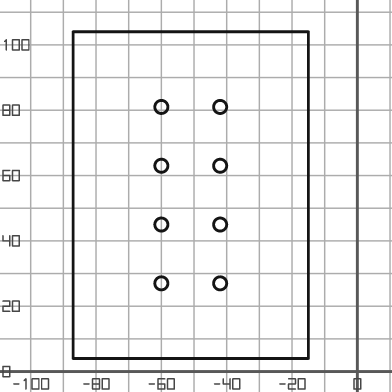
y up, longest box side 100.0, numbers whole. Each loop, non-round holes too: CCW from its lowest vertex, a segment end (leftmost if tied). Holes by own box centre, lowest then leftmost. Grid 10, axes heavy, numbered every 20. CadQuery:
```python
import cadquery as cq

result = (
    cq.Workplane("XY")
    .moveTo(-87.0, 4.0)
    .lineTo(-15.0, 4.0)
    .lineTo(-15.0, 104.0)
    .lineTo(-87.0, 104.0)
    .close()
    .moveTo(-60.0, 27.0)
    .circle(2.0)
    .moveTo(-42.0, 27.0)
    .circle(2.0)
    .moveTo(-60.0, 45.0)
    .circle(2.0)
    .moveTo(-42.0, 45.0)
    .circle(2.0)
    .moveTo(-60.0, 63.0)
    .circle(2.0)
    .moveTo(-42.0, 63.0)
    .circle(2.0)
    .moveTo(-60.0, 81.0)
    .circle(2.0)
    .moveTo(-42.0, 81.0)
    .circle(2.0)
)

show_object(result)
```